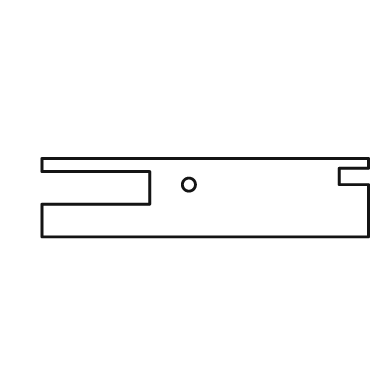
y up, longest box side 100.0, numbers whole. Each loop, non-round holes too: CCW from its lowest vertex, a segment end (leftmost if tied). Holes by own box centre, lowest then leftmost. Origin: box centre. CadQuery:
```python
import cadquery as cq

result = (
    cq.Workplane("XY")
    .moveTo(-50.0, -12.0)
    .lineTo(50.0, -12.0)
    .lineTo(50.0, 4.0)
    .lineTo(41.0, 4.0)
    .lineTo(41.0, 9.0)
    .lineTo(50.0, 9.0)
    .lineTo(50.0, 12.0)
    .lineTo(-50.0, 12.0)
    .lineTo(-50.0, 8.0)
    .lineTo(-17.0, 8.0)
    .lineTo(-17.0, -2.0)
    .lineTo(-50.0, -2.0)
    .close()
    .moveTo(-5.0, 4.0)
    .circle(2.0)
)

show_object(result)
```